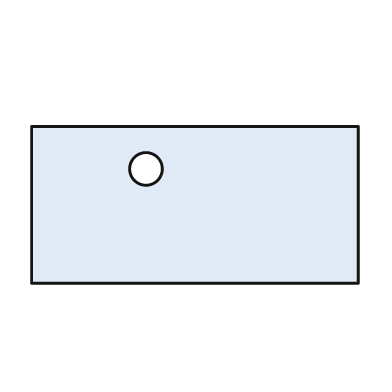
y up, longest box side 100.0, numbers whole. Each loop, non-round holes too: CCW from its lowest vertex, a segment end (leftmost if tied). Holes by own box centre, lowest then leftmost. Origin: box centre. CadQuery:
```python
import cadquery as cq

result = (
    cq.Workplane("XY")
    .moveTo(-50.0, -24.0)
    .lineTo(50.0, -24.0)
    .lineTo(50.0, 24.0)
    .lineTo(-50.0, 24.0)
    .close()
    .moveTo(-15.0, 11.0)
    .circle(5.0)
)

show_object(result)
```